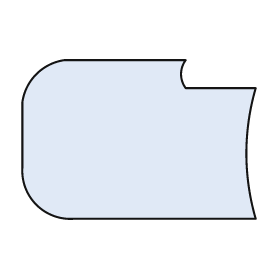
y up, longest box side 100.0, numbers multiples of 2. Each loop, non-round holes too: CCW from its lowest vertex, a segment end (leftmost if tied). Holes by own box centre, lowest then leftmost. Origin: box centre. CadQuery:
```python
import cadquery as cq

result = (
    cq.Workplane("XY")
    .moveTo(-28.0, -34.0)
    .lineTo(50.0, -34.0)
    .threePointArc((46.0, -6.0), (50.0, 22.0))
    .lineTo(20.0, 22.0)
    .threePointArc((18.0, 28.0), (20.0, 34.0))
    .lineTo(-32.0, 34.0)
    .threePointArc((-44.0, 28.0), (-50.0, 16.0))
    .lineTo(-50.0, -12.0)
    .threePointArc((-44.0, -28.0), (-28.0, -34.0))
    .close()
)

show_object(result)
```